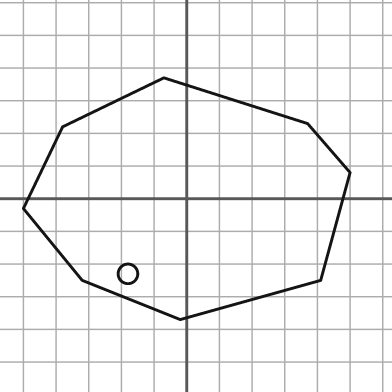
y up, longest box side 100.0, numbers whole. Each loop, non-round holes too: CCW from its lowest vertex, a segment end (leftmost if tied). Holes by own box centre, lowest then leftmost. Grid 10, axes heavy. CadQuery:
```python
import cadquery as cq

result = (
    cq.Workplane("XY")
    .moveTo(-2.0, -37.0)
    .lineTo(41.0, -25.0)
    .lineTo(50.0, 8.0)
    .lineTo(37.0, 23.0)
    .lineTo(-7.0, 37.0)
    .lineTo(-38.0, 22.0)
    .lineTo(-50.0, -3.0)
    .lineTo(-32.0, -25.0)
    .close()
    .moveTo(-18.0, -23.0)
    .circle(3.0)
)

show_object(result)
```